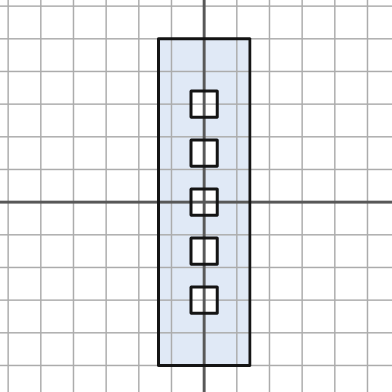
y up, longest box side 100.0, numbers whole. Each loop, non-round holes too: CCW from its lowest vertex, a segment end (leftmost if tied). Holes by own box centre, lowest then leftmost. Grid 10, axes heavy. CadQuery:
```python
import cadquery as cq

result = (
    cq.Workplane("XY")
    .moveTo(-14.0, -50.0)
    .lineTo(14.0, -50.0)
    .lineTo(14.0, 50.0)
    .lineTo(-14.0, 50.0)
    .close()
    .moveTo(-4.0, -34.0)
    .lineTo(4.0, -34.0)
    .lineTo(4.0, -26.0)
    .lineTo(-4.0, -26.0)
    .close()
    .moveTo(-4.0, -19.0)
    .lineTo(4.0, -19.0)
    .lineTo(4.0, -11.0)
    .lineTo(-4.0, -11.0)
    .close()
    .moveTo(-4.0, -4.0)
    .lineTo(4.0, -4.0)
    .lineTo(4.0, 4.0)
    .lineTo(-4.0, 4.0)
    .close()
    .moveTo(-4.0, 11.0)
    .lineTo(4.0, 11.0)
    .lineTo(4.0, 19.0)
    .lineTo(-4.0, 19.0)
    .close()
    .moveTo(-4.0, 26.0)
    .lineTo(4.0, 26.0)
    .lineTo(4.0, 34.0)
    .lineTo(-4.0, 34.0)
    .close()
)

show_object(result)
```